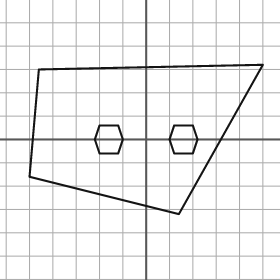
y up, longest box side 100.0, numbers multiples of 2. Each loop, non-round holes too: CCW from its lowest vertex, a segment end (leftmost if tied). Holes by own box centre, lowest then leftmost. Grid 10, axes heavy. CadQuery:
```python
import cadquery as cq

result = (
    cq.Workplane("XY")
    .moveTo(14.0, -32.0)
    .lineTo(50.0, 32.0)
    .lineTo(-46.0, 30.0)
    .lineTo(-50.0, -16.0)
    .close()
    .moveTo(-20.0, -6.0)
    .lineTo(-12.0, -6.0)
    .lineTo(-10.0, 0.0)
    .lineTo(-12.0, 6.0)
    .lineTo(-20.0, 6.0)
    .lineTo(-22.0, 0.0)
    .close()
    .moveTo(12.0, -6.0)
    .lineTo(20.0, -6.0)
    .lineTo(22.0, 0.0)
    .lineTo(20.0, 6.0)
    .lineTo(12.0, 6.0)
    .lineTo(10.0, 0.0)
    .close()
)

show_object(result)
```